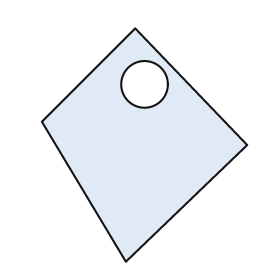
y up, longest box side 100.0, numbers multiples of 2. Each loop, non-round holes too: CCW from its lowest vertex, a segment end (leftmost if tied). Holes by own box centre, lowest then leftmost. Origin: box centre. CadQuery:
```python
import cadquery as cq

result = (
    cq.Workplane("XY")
    .moveTo(-8.0, -50.0)
    .lineTo(44.0, 0.0)
    .lineTo(-4.0, 50.0)
    .lineTo(-44.0, 10.0)
    .close()
    .moveTo(0.0, 26.0)
    .circle(10.0)
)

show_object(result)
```